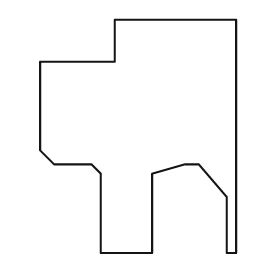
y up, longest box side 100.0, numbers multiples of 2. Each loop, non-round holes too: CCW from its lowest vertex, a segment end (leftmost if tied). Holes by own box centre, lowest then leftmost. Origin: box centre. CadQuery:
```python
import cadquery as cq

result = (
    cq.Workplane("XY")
    .moveTo(-16.0, -50.0)
    .lineTo(6.0, -50.0)
    .lineTo(6.0, -16.0)
    .lineTo(20.0, -12.0)
    .lineTo(26.0, -12.0)
    .lineTo(38.0, -26.0)
    .lineTo(38.0, -50.0)
    .lineTo(42.0, -50.0)
    .lineTo(42.0, 50.0)
    .lineTo(-10.0, 50.0)
    .lineTo(-10.0, 32.0)
    .lineTo(-42.0, 32.0)
    .lineTo(-42.0, -6.0)
    .lineTo(-36.0, -12.0)
    .lineTo(-20.0, -12.0)
    .lineTo(-16.0, -16.0)
    .close()
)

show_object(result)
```